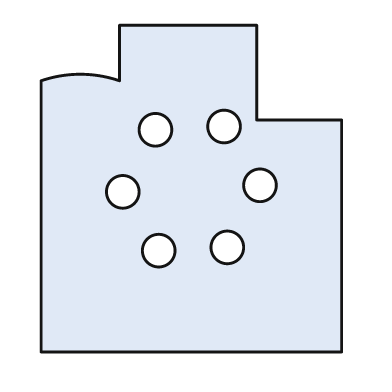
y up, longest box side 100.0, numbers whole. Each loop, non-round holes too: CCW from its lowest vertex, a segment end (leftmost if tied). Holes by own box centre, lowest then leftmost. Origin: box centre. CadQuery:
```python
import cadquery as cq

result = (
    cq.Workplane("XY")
    .moveTo(-46.0, -50.0)
    .lineTo(46.0, -50.0)
    .lineTo(46.0, 21.0)
    .lineTo(20.0, 21.0)
    .lineTo(20.0, 50.0)
    .lineTo(-22.0, 50.0)
    .lineTo(-22.0, 33.0)
    .threePointArc((-34.0, 35.0), (-46.0, 33.0))
    .close()
    .moveTo(-10.0, -19.0)
    .circle(5.0)
    .moveTo(11.0, -18.0)
    .circle(5.0)
    .moveTo(-21.0, -1.0)
    .circle(5.0)
    .moveTo(21.0, 1.0)
    .circle(5.0)
    .moveTo(-11.0, 18.0)
    .circle(5.0)
    .moveTo(10.0, 19.0)
    .circle(5.0)
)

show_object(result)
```